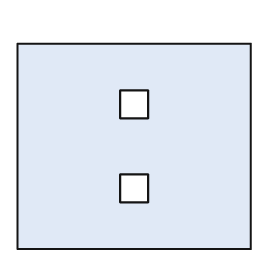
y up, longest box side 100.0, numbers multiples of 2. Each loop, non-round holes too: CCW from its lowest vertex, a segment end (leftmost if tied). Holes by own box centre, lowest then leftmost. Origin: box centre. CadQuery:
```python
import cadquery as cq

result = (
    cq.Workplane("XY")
    .moveTo(-50.0, -44.0)
    .lineTo(50.0, -44.0)
    .lineTo(50.0, 44.0)
    .lineTo(-50.0, 44.0)
    .close()
    .moveTo(-6.0, -24.0)
    .lineTo(6.0, -24.0)
    .lineTo(6.0, -12.0)
    .lineTo(-6.0, -12.0)
    .close()
    .moveTo(-6.0, 12.0)
    .lineTo(6.0, 12.0)
    .lineTo(6.0, 24.0)
    .lineTo(-6.0, 24.0)
    .close()
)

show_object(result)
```